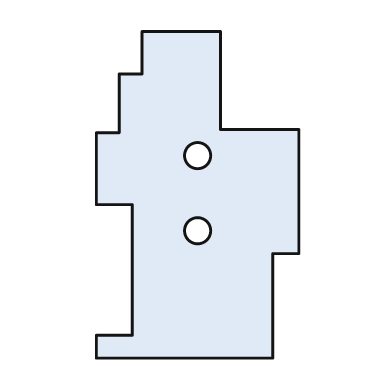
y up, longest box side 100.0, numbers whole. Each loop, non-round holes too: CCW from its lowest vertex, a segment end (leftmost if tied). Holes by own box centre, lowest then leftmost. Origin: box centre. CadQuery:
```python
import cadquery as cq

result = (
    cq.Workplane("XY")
    .moveTo(-31.0, -50.0)
    .lineTo(23.0, -50.0)
    .lineTo(23.0, -18.0)
    .lineTo(31.0, -18.0)
    .lineTo(31.0, 20.0)
    .lineTo(7.0, 20.0)
    .lineTo(7.0, 50.0)
    .lineTo(-17.0, 50.0)
    .lineTo(-17.0, 37.0)
    .lineTo(-24.0, 37.0)
    .lineTo(-24.0, 19.0)
    .lineTo(-31.0, 19.0)
    .lineTo(-31.0, -3.0)
    .lineTo(-20.0, -3.0)
    .lineTo(-20.0, -43.0)
    .lineTo(-31.0, -43.0)
    .close()
    .moveTo(0.0, -11.0)
    .circle(4.0)
    .moveTo(0.0, 12.0)
    .circle(4.0)
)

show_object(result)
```